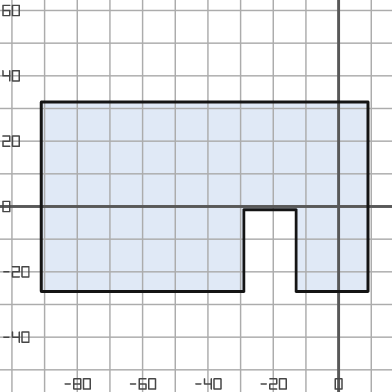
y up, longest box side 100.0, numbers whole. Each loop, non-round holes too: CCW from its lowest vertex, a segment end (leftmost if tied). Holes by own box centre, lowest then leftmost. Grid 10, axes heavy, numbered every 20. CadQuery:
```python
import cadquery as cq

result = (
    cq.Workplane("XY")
    .moveTo(-91.0, -26.0)
    .lineTo(-29.0, -26.0)
    .lineTo(-29.0, -1.0)
    .lineTo(-13.0, -1.0)
    .lineTo(-13.0, -26.0)
    .lineTo(9.0, -26.0)
    .lineTo(9.0, 32.0)
    .lineTo(-91.0, 32.0)
    .close()
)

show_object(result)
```